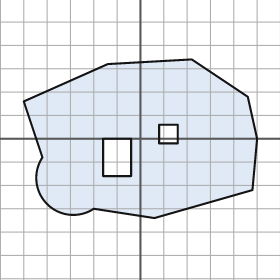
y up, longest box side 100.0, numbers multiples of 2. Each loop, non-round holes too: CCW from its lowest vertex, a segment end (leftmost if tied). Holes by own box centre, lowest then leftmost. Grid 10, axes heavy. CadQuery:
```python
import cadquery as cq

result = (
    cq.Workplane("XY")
    .moveTo(6.0, -34.0)
    .lineTo(48.0, -22.0)
    .lineTo(50.0, 0.0)
    .lineTo(46.0, 18.0)
    .lineTo(22.0, 34.0)
    .lineTo(-14.0, 32.0)
    .lineTo(-50.0, 16.0)
    .lineTo(-42.0, -8.0)
    .threePointArc((-40.0, -28.0), (-20.0, -30.0))
    .close()
    .moveTo(-16.0, -16.0)
    .lineTo(-4.0, -16.0)
    .lineTo(-4.0, 0.0)
    .lineTo(-16.0, 0.0)
    .close()
    .moveTo(8.0, -2.0)
    .lineTo(16.0, -2.0)
    .lineTo(16.0, 6.0)
    .lineTo(8.0, 6.0)
    .close()
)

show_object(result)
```